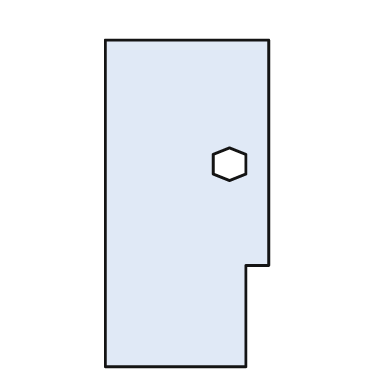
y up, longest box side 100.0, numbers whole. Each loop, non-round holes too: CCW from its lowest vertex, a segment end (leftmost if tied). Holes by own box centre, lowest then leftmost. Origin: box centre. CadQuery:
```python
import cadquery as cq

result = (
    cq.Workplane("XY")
    .moveTo(-25.0, -50.0)
    .lineTo(18.0, -50.0)
    .lineTo(18.0, -19.0)
    .lineTo(25.0, -19.0)
    .lineTo(25.0, 50.0)
    .lineTo(-25.0, 50.0)
    .close()
    .moveTo(13.0, 7.0)
    .lineTo(18.0, 9.0)
    .lineTo(18.0, 15.0)
    .lineTo(13.0, 17.0)
    .lineTo(8.0, 15.0)
    .lineTo(8.0, 9.0)
    .close()
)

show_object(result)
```